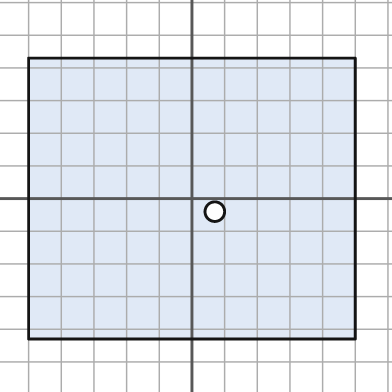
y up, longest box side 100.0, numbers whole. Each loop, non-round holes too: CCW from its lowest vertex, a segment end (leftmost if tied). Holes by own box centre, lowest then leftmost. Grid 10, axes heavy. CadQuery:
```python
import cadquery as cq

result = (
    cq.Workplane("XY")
    .moveTo(-50.0, -43.0)
    .lineTo(50.0, -43.0)
    .lineTo(50.0, 43.0)
    .lineTo(-50.0, 43.0)
    .close()
    .moveTo(7.0, -4.0)
    .circle(3.0)
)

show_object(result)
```